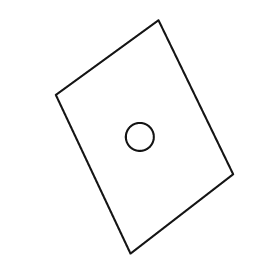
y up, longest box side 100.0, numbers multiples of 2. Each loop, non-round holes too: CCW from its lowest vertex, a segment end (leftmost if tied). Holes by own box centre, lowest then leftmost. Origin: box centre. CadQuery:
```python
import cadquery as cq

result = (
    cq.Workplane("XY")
    .moveTo(-6.0, -50.0)
    .lineTo(38.0, -16.0)
    .lineTo(6.0, 50.0)
    .lineTo(-38.0, 18.0)
    .close()
    .moveTo(-2.0, 0.0)
    .circle(6.0)
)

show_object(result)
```